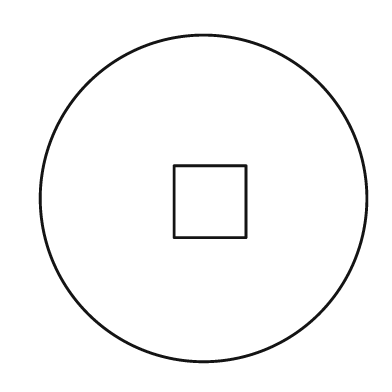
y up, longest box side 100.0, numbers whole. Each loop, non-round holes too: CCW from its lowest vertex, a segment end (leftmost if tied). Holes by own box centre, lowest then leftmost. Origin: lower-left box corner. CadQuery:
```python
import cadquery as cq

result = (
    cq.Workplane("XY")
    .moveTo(50.0, 50.0)
    .circle(50.0)
    .moveTo(41.0, 38.0)
    .lineTo(63.0, 38.0)
    .lineTo(63.0, 60.0)
    .lineTo(41.0, 60.0)
    .close()
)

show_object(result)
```